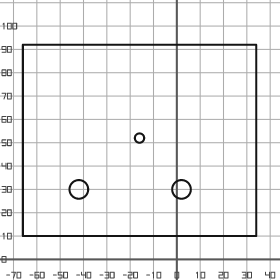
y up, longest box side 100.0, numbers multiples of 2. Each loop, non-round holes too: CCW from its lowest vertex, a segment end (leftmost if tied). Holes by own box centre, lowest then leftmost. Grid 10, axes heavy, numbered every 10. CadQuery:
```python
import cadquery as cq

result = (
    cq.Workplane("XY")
    .moveTo(-66.0, 10.0)
    .lineTo(34.0, 10.0)
    .lineTo(34.0, 92.0)
    .lineTo(-66.0, 92.0)
    .close()
    .moveTo(-42.0, 30.0)
    .circle(4.0)
    .moveTo(2.0, 30.0)
    .circle(4.0)
    .moveTo(-16.0, 52.0)
    .circle(2.0)
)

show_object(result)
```